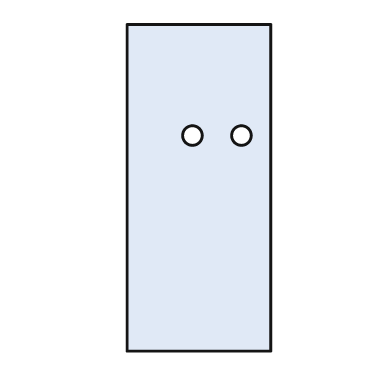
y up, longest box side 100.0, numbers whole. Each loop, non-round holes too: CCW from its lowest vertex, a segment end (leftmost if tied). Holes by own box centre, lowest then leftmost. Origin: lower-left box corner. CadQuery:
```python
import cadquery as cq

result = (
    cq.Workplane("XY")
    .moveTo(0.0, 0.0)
    .lineTo(44.0, 0.0)
    .lineTo(44.0, 100.0)
    .lineTo(0.0, 100.0)
    .close()
    .moveTo(20.0, 66.0)
    .circle(3.0)
    .moveTo(35.0, 66.0)
    .circle(3.0)
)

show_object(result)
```